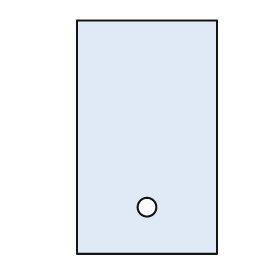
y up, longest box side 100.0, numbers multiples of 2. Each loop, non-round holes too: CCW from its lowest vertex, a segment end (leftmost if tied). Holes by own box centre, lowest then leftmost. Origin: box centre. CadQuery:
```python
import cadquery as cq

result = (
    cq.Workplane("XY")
    .moveTo(-30.0, -50.0)
    .lineTo(30.0, -50.0)
    .lineTo(30.0, 50.0)
    .lineTo(-30.0, 50.0)
    .close()
    .moveTo(0.0, -30.0)
    .circle(4.0)
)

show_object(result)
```